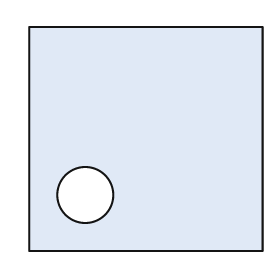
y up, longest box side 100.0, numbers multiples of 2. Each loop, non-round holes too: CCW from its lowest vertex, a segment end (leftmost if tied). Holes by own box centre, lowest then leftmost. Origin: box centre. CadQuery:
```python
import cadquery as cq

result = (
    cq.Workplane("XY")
    .moveTo(-50.0, -48.0)
    .lineTo(50.0, -48.0)
    .lineTo(50.0, 48.0)
    .lineTo(-50.0, 48.0)
    .close()
    .moveTo(-26.0, -24.0)
    .circle(12.0)
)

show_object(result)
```